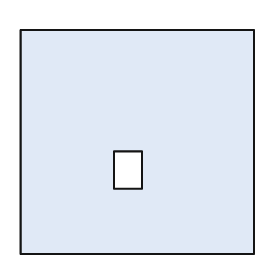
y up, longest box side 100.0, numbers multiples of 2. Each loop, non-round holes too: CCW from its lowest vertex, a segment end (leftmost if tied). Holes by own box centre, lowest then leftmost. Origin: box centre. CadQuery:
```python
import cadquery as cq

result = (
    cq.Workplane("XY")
    .moveTo(-50.0, -48.0)
    .lineTo(50.0, -48.0)
    .lineTo(50.0, 48.0)
    .lineTo(-50.0, 48.0)
    .close()
    .moveTo(-10.0, -20.0)
    .lineTo(2.0, -20.0)
    .lineTo(2.0, -4.0)
    .lineTo(-10.0, -4.0)
    .close()
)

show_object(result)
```